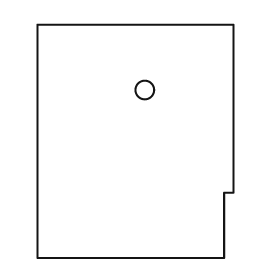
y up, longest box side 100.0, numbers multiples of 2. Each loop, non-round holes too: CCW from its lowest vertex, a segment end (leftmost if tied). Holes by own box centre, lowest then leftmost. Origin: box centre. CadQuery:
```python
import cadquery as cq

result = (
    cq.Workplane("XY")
    .moveTo(-42.0, -50.0)
    .lineTo(38.0, -50.0)
    .lineTo(38.0, -22.0)
    .lineTo(42.0, -22.0)
    .lineTo(42.0, 50.0)
    .lineTo(-42.0, 50.0)
    .close()
    .moveTo(4.0, 22.0)
    .circle(4.0)
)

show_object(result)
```